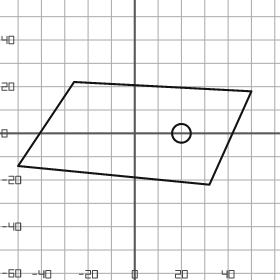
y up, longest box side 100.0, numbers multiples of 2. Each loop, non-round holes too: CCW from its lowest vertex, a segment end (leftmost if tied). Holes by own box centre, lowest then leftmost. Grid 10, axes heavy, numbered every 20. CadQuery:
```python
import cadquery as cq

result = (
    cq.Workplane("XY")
    .moveTo(32.0, -22.0)
    .lineTo(50.0, 18.0)
    .lineTo(-26.0, 22.0)
    .lineTo(-50.0, -14.0)
    .close()
    .moveTo(20.0, 0.0)
    .circle(4.0)
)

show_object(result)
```